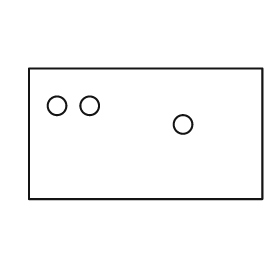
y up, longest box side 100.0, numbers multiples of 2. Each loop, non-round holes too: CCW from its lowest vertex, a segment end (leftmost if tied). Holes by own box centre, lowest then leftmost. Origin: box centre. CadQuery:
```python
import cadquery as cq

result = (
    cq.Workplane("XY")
    .moveTo(-50.0, -28.0)
    .lineTo(50.0, -28.0)
    .lineTo(50.0, 28.0)
    .lineTo(-50.0, 28.0)
    .close()
    .moveTo(16.0, 4.0)
    .circle(4.0)
    .moveTo(-38.0, 12.0)
    .circle(4.0)
    .moveTo(-24.0, 12.0)
    .circle(4.0)
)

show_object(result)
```